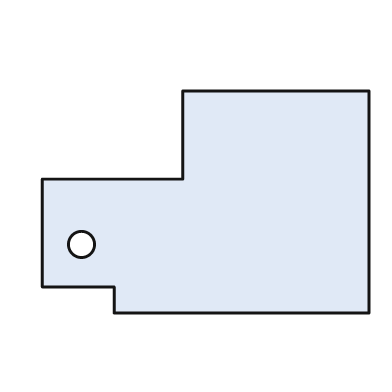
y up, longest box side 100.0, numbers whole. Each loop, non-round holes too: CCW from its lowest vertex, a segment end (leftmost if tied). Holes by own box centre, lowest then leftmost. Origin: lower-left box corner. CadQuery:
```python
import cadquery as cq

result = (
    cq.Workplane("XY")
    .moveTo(22.0, 0.0)
    .lineTo(100.0, 0.0)
    .lineTo(100.0, 68.0)
    .lineTo(43.0, 68.0)
    .lineTo(43.0, 41.0)
    .lineTo(0.0, 41.0)
    .lineTo(0.0, 8.0)
    .lineTo(22.0, 8.0)
    .close()
    .moveTo(12.0, 21.0)
    .circle(4.0)
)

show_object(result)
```